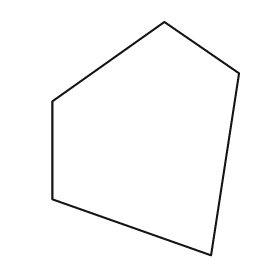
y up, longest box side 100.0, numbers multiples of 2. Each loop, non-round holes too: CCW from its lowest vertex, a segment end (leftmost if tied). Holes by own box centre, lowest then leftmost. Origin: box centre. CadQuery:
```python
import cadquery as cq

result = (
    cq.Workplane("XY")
    .moveTo(28.0, -50.0)
    .lineTo(40.0, 28.0)
    .lineTo(8.0, 50.0)
    .lineTo(-40.0, 16.0)
    .lineTo(-40.0, -26.0)
    .close()
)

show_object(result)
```